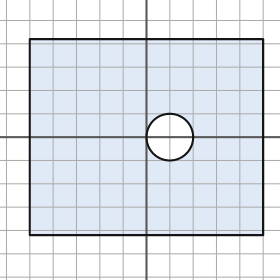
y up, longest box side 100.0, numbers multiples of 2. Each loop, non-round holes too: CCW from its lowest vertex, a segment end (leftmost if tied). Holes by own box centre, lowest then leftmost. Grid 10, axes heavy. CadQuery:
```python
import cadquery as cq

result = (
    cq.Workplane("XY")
    .moveTo(-50.0, -42.0)
    .lineTo(50.0, -42.0)
    .lineTo(50.0, 42.0)
    .lineTo(-50.0, 42.0)
    .close()
    .moveTo(10.0, 0.0)
    .circle(10.0)
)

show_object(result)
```